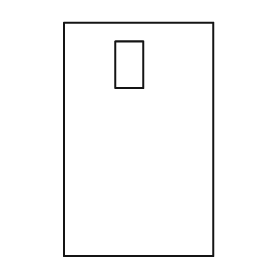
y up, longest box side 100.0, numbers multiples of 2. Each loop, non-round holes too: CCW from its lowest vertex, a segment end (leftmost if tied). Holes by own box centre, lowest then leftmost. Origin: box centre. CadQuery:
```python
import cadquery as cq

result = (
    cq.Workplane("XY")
    .moveTo(-32.0, -50.0)
    .lineTo(32.0, -50.0)
    .lineTo(32.0, 50.0)
    .lineTo(-32.0, 50.0)
    .close()
    .moveTo(-10.0, 22.0)
    .lineTo(2.0, 22.0)
    .lineTo(2.0, 42.0)
    .lineTo(-10.0, 42.0)
    .close()
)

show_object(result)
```